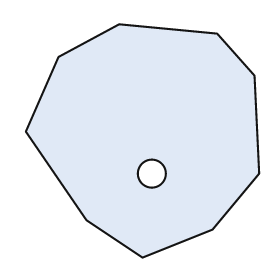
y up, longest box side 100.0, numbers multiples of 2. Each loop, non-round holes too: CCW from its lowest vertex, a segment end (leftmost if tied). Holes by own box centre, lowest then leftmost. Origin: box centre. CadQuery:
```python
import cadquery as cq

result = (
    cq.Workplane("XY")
    .moveTo(0.0, -50.0)
    .lineTo(30.0, -38.0)
    .lineTo(50.0, -14.0)
    .lineTo(48.0, 28.0)
    .lineTo(32.0, 46.0)
    .lineTo(-10.0, 50.0)
    .lineTo(-36.0, 36.0)
    .lineTo(-50.0, 4.0)
    .lineTo(-24.0, -34.0)
    .close()
    .moveTo(4.0, -14.0)
    .circle(6.0)
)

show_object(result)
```